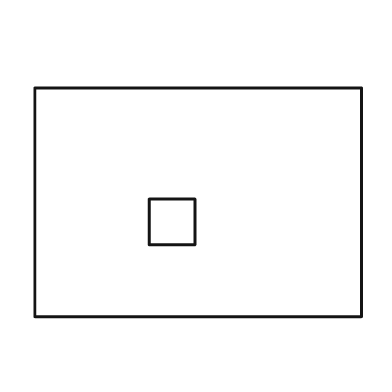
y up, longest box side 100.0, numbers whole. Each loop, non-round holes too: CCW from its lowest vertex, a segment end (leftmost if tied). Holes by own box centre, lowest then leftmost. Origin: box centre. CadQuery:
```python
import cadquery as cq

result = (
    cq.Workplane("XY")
    .moveTo(-50.0, -35.0)
    .lineTo(50.0, -35.0)
    .lineTo(50.0, 35.0)
    .lineTo(-50.0, 35.0)
    .close()
    .moveTo(-15.0, -13.0)
    .lineTo(-1.0, -13.0)
    .lineTo(-1.0, 1.0)
    .lineTo(-15.0, 1.0)
    .close()
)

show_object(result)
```